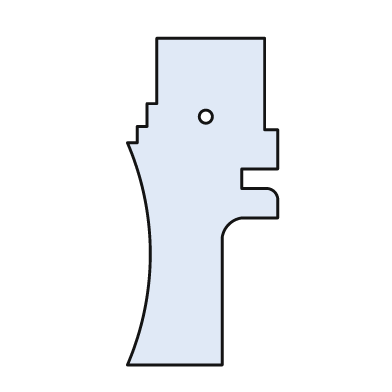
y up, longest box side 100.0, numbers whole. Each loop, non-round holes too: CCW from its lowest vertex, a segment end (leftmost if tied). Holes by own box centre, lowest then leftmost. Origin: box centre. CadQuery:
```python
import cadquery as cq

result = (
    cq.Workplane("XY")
    .moveTo(-23.0, -50.0)
    .lineTo(6.0, -50.0)
    .lineTo(6.0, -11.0)
    .threePointArc((8.0, -7.0), (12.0, -5.0))
    .lineTo(23.0, -5.0)
    .lineTo(23.0, 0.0)
    .threePointArc((22.0, 3.0), (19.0, 4.0))
    .lineTo(12.0, 4.0)
    .lineTo(12.0, 10.0)
    .lineTo(23.0, 10.0)
    .lineTo(23.0, 22.0)
    .lineTo(19.0, 22.0)
    .lineTo(19.0, 50.0)
    .lineTo(-14.0, 50.0)
    .lineTo(-14.0, 30.0)
    .lineTo(-17.0, 30.0)
    .lineTo(-17.0, 23.0)
    .lineTo(-20.0, 23.0)
    .lineTo(-20.0, 18.0)
    .lineTo(-23.0, 18.0)
    .threePointArc((-16.0, -16.0), (-23.0, -50.0))
    .close()
    .moveTo(1.0, 26.0)
    .circle(2.0)
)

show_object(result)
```